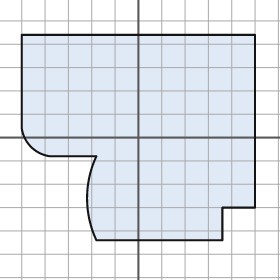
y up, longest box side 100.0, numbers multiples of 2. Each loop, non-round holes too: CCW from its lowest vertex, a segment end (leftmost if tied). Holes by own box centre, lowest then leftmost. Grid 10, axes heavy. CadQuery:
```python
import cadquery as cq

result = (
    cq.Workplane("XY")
    .moveTo(-18.0, -44.0)
    .lineTo(36.0, -44.0)
    .lineTo(36.0, -30.0)
    .lineTo(50.0, -30.0)
    .lineTo(50.0, 44.0)
    .lineTo(-50.0, 44.0)
    .lineTo(-50.0, 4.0)
    .threePointArc((-46.0, -4.0), (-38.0, -8.0))
    .lineTo(-18.0, -8.0)
    .threePointArc((-22.0, -26.0), (-18.0, -44.0))
    .close()
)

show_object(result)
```